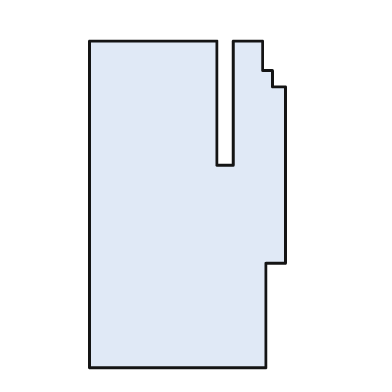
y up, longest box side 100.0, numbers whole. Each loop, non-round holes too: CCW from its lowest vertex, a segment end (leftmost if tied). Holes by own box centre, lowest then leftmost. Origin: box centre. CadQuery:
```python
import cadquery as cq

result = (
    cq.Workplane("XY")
    .moveTo(-30.0, -50.0)
    .lineTo(24.0, -50.0)
    .lineTo(24.0, -18.0)
    .lineTo(30.0, -18.0)
    .lineTo(30.0, 36.0)
    .lineTo(26.0, 36.0)
    .lineTo(26.0, 41.0)
    .lineTo(23.0, 41.0)
    .lineTo(23.0, 50.0)
    .lineTo(14.0, 50.0)
    .lineTo(14.0, 12.0)
    .lineTo(9.0, 12.0)
    .lineTo(9.0, 50.0)
    .lineTo(-30.0, 50.0)
    .close()
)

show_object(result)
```